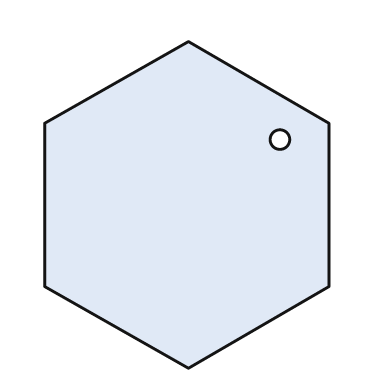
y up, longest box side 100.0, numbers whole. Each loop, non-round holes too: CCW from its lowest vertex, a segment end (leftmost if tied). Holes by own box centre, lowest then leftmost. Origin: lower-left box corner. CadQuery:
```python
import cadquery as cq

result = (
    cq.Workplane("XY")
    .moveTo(44.0, 0.0)
    .lineTo(87.0, 25.0)
    .lineTo(87.0, 75.0)
    .lineTo(44.0, 100.0)
    .lineTo(0.0, 75.0)
    .lineTo(0.0, 25.0)
    .close()
    .moveTo(72.0, 70.0)
    .circle(3.0)
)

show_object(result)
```